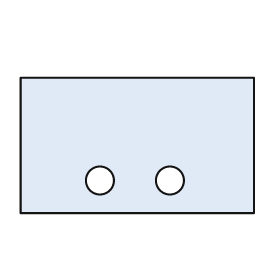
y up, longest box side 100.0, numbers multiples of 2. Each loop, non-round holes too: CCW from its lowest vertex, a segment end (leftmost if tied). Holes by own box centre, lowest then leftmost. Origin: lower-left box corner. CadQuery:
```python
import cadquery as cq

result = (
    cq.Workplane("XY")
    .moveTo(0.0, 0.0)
    .lineTo(100.0, 0.0)
    .lineTo(100.0, 58.0)
    .lineTo(0.0, 58.0)
    .close()
    .moveTo(34.0, 14.0)
    .circle(6.0)
    .moveTo(64.0, 14.0)
    .circle(6.0)
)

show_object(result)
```